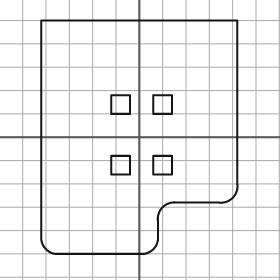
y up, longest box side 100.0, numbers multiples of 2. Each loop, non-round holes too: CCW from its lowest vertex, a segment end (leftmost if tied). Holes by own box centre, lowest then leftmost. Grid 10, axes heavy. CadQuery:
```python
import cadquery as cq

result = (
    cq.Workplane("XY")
    .moveTo(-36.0, -50.0)
    .lineTo(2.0, -50.0)
    .threePointArc((6.0, -48.0), (8.0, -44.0))
    .lineTo(8.0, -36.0)
    .threePointArc((10.0, -30.0), (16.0, -28.0))
    .lineTo(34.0, -28.0)
    .threePointArc((40.0, -26.0), (42.0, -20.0))
    .lineTo(42.0, 50.0)
    .lineTo(-42.0, 50.0)
    .lineTo(-42.0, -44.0)
    .threePointArc((-40.0, -48.0), (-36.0, -50.0))
    .close()
    .moveTo(-12.0, -16.0)
    .lineTo(-4.0, -16.0)
    .lineTo(-4.0, -8.0)
    .lineTo(-12.0, -8.0)
    .close()
    .moveTo(6.0, -16.0)
    .lineTo(14.0, -16.0)
    .lineTo(14.0, -8.0)
    .lineTo(6.0, -8.0)
    .close()
    .moveTo(-12.0, 10.0)
    .lineTo(-4.0, 10.0)
    .lineTo(-4.0, 18.0)
    .lineTo(-12.0, 18.0)
    .close()
    .moveTo(6.0, 10.0)
    .lineTo(14.0, 10.0)
    .lineTo(14.0, 18.0)
    .lineTo(6.0, 18.0)
    .close()
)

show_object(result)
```